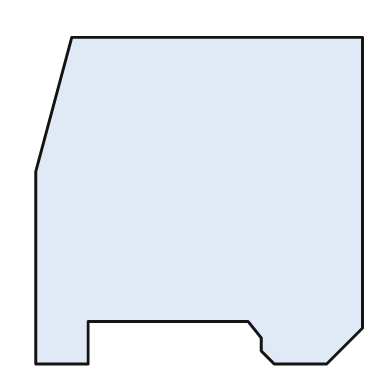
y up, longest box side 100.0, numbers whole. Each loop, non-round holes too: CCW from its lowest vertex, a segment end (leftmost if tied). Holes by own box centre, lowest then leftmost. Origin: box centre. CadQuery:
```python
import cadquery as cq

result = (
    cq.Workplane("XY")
    .moveTo(-50.0, -50.0)
    .lineTo(-34.0, -50.0)
    .lineTo(-34.0, -37.0)
    .lineTo(15.0, -37.0)
    .lineTo(19.0, -42.0)
    .lineTo(19.0, -46.0)
    .lineTo(23.0, -50.0)
    .lineTo(39.0, -50.0)
    .lineTo(50.0, -39.0)
    .lineTo(50.0, 50.0)
    .lineTo(-39.0, 50.0)
    .lineTo(-50.0, 9.0)
    .close()
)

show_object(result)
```